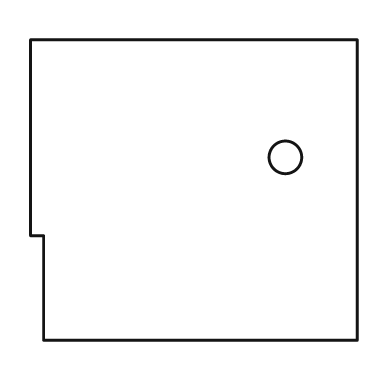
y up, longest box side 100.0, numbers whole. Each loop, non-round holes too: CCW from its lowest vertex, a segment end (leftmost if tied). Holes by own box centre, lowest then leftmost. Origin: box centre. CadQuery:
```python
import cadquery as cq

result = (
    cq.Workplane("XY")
    .moveTo(-46.0, -46.0)
    .lineTo(50.0, -46.0)
    .lineTo(50.0, 46.0)
    .lineTo(-50.0, 46.0)
    .lineTo(-50.0, -14.0)
    .lineTo(-46.0, -14.0)
    .close()
    .moveTo(28.0, 10.0)
    .circle(5.0)
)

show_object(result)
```